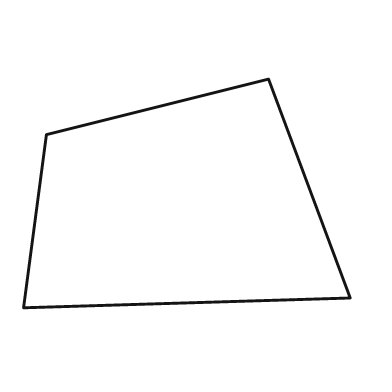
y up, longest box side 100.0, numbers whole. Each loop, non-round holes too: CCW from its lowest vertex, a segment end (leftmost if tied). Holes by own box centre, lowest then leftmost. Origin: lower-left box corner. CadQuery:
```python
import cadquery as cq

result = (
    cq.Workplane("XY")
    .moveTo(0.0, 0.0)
    .lineTo(100.0, 3.0)
    .lineTo(75.0, 70.0)
    .lineTo(7.0, 53.0)
    .close()
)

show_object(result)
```